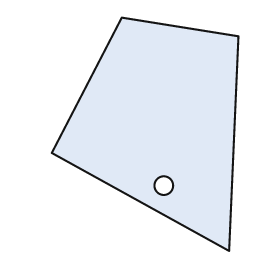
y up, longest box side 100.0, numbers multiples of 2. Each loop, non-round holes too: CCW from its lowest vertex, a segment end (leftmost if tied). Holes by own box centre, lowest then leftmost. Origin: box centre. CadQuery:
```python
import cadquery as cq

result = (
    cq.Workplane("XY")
    .moveTo(36.0, -50.0)
    .lineTo(40.0, 42.0)
    .lineTo(-10.0, 50.0)
    .lineTo(-40.0, -8.0)
    .close()
    .moveTo(8.0, -22.0)
    .circle(4.0)
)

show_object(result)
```